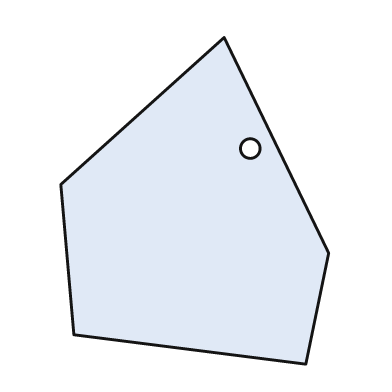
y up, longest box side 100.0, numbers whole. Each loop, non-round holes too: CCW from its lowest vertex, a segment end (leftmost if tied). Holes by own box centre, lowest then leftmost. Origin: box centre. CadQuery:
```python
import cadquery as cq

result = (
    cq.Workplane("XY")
    .moveTo(34.0, -50.0)
    .lineTo(41.0, -16.0)
    .lineTo(9.0, 50.0)
    .lineTo(-41.0, 5.0)
    .lineTo(-37.0, -41.0)
    .close()
    .moveTo(17.0, 16.0)
    .circle(3.0)
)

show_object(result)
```